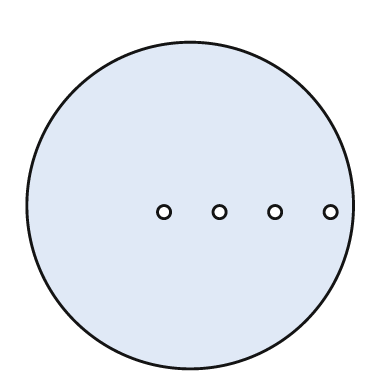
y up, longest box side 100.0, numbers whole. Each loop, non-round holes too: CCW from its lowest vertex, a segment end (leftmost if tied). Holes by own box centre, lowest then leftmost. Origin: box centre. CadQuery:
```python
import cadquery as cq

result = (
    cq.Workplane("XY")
    .moveTo(0.0, 0.0)
    .circle(50.0)
    .moveTo(-8.0, -2.0)
    .circle(2.0)
    .moveTo(9.0, -2.0)
    .circle(2.0)
    .moveTo(26.0, -2.0)
    .circle(2.0)
    .moveTo(43.0, -2.0)
    .circle(2.0)
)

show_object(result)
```